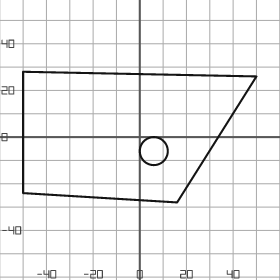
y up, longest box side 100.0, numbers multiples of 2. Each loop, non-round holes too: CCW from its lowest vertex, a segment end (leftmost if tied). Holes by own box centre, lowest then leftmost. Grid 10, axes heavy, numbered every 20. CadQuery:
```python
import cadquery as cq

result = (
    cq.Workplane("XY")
    .moveTo(16.0, -28.0)
    .lineTo(50.0, 26.0)
    .lineTo(-50.0, 28.0)
    .lineTo(-50.0, -24.0)
    .close()
    .moveTo(6.0, -6.0)
    .circle(6.0)
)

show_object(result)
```